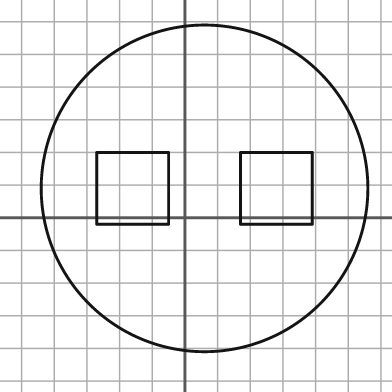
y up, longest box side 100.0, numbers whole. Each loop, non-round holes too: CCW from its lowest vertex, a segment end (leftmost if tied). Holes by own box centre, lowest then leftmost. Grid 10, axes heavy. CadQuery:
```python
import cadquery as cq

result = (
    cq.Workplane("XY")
    .moveTo(6.0, 9.0)
    .circle(50.0)
    .moveTo(-27.0, -2.0)
    .lineTo(-5.0, -2.0)
    .lineTo(-5.0, 20.0)
    .lineTo(-27.0, 20.0)
    .close()
    .moveTo(17.0, -2.0)
    .lineTo(39.0, -2.0)
    .lineTo(39.0, 20.0)
    .lineTo(17.0, 20.0)
    .close()
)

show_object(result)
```